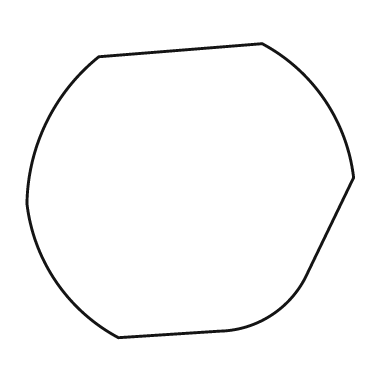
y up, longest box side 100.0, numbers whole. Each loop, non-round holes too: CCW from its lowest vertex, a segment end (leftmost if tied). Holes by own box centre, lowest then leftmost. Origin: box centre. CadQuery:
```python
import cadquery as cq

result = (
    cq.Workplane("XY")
    .moveTo(-22.0, -45.0)
    .lineTo(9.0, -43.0)
    .threePointArc((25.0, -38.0), (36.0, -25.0))
    .lineTo(50.0, 4.0)
    .threePointArc((41.0, 28.0), (22.0, 45.0))
    .lineTo(-28.0, 41.0)
    .threePointArc((-44.0, 21.0), (-50.0, -4.0))
    .threePointArc((-41.0, -28.0), (-22.0, -45.0))
    .close()
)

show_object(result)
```